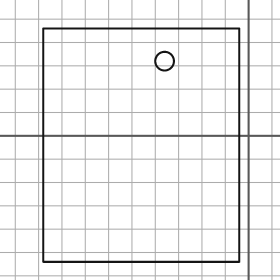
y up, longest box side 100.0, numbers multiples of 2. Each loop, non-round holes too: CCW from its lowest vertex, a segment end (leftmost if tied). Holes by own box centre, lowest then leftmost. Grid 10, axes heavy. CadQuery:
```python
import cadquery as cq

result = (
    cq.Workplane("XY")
    .moveTo(-88.0, -54.0)
    .lineTo(-4.0, -54.0)
    .lineTo(-4.0, 46.0)
    .lineTo(-88.0, 46.0)
    .close()
    .moveTo(-36.0, 32.0)
    .circle(4.0)
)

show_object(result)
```